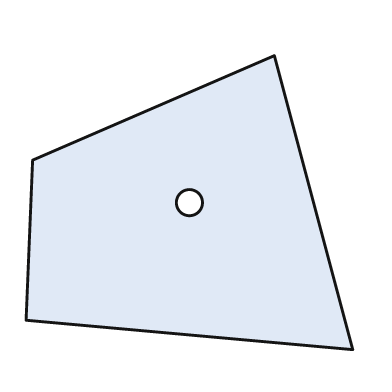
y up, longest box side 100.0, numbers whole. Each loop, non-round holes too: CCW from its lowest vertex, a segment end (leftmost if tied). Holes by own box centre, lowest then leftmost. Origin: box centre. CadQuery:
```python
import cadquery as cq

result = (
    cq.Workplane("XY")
    .moveTo(50.0, -45.0)
    .lineTo(26.0, 45.0)
    .lineTo(-48.0, 13.0)
    .lineTo(-50.0, -36.0)
    .close()
    .moveTo(0.0, 0.0)
    .circle(4.0)
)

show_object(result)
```